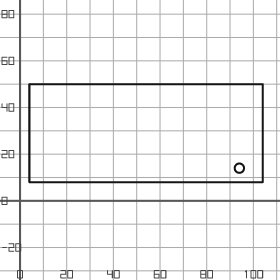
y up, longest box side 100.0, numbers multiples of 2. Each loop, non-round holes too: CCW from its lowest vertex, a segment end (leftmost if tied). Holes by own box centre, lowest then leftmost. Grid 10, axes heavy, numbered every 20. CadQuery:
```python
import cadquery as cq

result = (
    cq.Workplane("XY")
    .moveTo(4.0, 8.0)
    .lineTo(104.0, 8.0)
    .lineTo(104.0, 50.0)
    .lineTo(4.0, 50.0)
    .close()
    .moveTo(94.0, 14.0)
    .circle(2.0)
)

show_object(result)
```